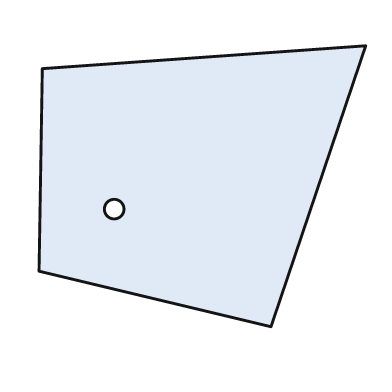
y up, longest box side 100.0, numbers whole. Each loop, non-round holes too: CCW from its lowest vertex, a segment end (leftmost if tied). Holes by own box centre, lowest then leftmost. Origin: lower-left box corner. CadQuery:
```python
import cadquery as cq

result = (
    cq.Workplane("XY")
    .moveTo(71.0, 0.0)
    .lineTo(100.0, 86.0)
    .lineTo(1.0, 79.0)
    .lineTo(0.0, 17.0)
    .close()
    .moveTo(23.0, 36.0)
    .circle(3.0)
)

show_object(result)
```